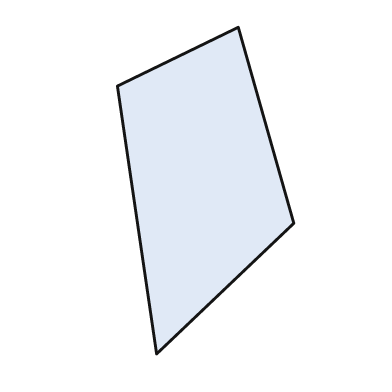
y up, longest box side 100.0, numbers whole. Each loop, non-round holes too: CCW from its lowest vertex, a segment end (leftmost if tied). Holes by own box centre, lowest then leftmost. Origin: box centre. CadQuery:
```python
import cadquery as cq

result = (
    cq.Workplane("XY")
    .moveTo(-15.0, -50.0)
    .lineTo(27.0, -10.0)
    .lineTo(10.0, 50.0)
    .lineTo(-27.0, 32.0)
    .close()
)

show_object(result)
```